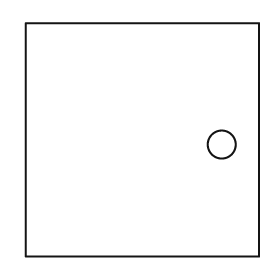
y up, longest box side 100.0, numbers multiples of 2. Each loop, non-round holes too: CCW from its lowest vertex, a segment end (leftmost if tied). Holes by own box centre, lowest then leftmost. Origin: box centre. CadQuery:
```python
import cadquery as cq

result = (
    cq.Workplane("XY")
    .moveTo(-50.0, -50.0)
    .lineTo(50.0, -50.0)
    .lineTo(50.0, 50.0)
    .lineTo(-50.0, 50.0)
    .close()
    .moveTo(34.0, -2.0)
    .circle(6.0)
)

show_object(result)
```